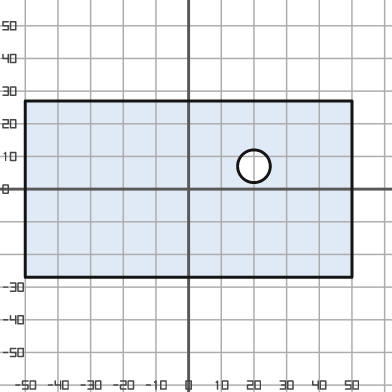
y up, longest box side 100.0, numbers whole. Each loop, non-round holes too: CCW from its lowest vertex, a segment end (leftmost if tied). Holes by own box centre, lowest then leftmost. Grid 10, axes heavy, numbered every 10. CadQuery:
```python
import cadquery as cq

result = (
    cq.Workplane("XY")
    .moveTo(-50.0, -27.0)
    .lineTo(50.0, -27.0)
    .lineTo(50.0, 27.0)
    .lineTo(-50.0, 27.0)
    .close()
    .moveTo(20.0, 7.0)
    .circle(5.0)
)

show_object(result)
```